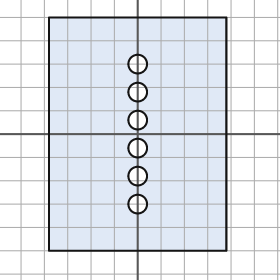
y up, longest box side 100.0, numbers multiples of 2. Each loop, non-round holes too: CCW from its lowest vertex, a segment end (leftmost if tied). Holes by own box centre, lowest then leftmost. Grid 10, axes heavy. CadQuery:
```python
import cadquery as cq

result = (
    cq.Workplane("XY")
    .moveTo(-38.0, -50.0)
    .lineTo(38.0, -50.0)
    .lineTo(38.0, 50.0)
    .lineTo(-38.0, 50.0)
    .close()
    .moveTo(0.0, -30.0)
    .circle(4.0)
    .moveTo(0.0, -18.0)
    .circle(4.0)
    .moveTo(0.0, -6.0)
    .circle(4.0)
    .moveTo(0.0, 6.0)
    .circle(4.0)
    .moveTo(0.0, 18.0)
    .circle(4.0)
    .moveTo(0.0, 30.0)
    .circle(4.0)
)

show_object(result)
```